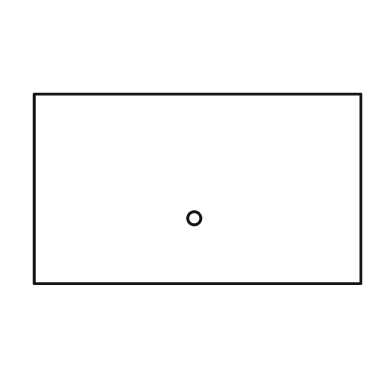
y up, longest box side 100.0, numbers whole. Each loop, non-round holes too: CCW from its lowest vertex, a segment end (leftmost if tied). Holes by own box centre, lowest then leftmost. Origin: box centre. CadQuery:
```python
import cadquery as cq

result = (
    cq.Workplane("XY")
    .moveTo(-50.0, -29.0)
    .lineTo(50.0, -29.0)
    .lineTo(50.0, 29.0)
    .lineTo(-50.0, 29.0)
    .close()
    .moveTo(-1.0, -9.0)
    .circle(2.0)
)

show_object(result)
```